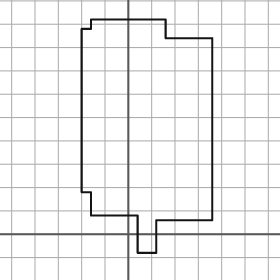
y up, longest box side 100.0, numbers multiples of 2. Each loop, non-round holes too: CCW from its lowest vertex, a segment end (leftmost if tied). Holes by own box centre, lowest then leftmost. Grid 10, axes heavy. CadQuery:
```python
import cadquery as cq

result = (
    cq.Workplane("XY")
    .moveTo(4.0, -8.0)
    .lineTo(12.0, -8.0)
    .lineTo(12.0, 6.0)
    .lineTo(36.0, 6.0)
    .lineTo(36.0, 84.0)
    .lineTo(16.0, 84.0)
    .lineTo(16.0, 92.0)
    .lineTo(-16.0, 92.0)
    .lineTo(-16.0, 88.0)
    .lineTo(-20.0, 88.0)
    .lineTo(-20.0, 18.0)
    .lineTo(-16.0, 18.0)
    .lineTo(-16.0, 8.0)
    .lineTo(4.0, 8.0)
    .close()
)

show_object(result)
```